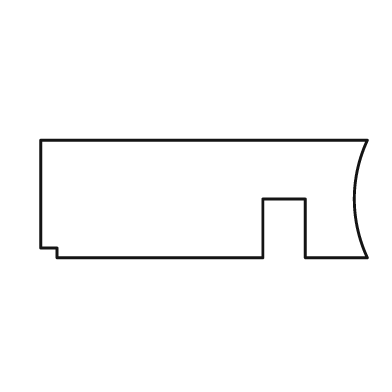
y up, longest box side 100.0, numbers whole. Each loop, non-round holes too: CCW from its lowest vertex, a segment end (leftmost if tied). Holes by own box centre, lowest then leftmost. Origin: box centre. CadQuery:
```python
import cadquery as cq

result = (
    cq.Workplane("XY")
    .moveTo(-45.0, -18.0)
    .lineTo(18.0, -18.0)
    .lineTo(18.0, 0.0)
    .lineTo(31.0, 0.0)
    .lineTo(31.0, -18.0)
    .lineTo(50.0, -18.0)
    .threePointArc((46.0, 0.0), (50.0, 18.0))
    .lineTo(-50.0, 18.0)
    .lineTo(-50.0, -15.0)
    .lineTo(-45.0, -15.0)
    .close()
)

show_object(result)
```